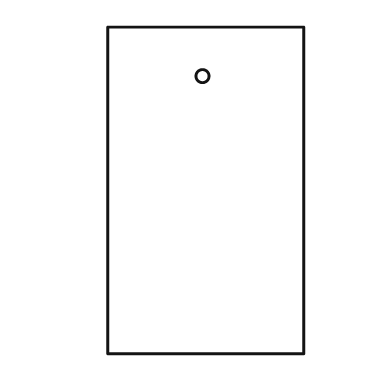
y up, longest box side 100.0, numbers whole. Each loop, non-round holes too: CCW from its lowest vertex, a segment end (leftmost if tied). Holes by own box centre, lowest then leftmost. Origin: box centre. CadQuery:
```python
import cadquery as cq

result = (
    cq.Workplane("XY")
    .moveTo(-30.0, -50.0)
    .lineTo(30.0, -50.0)
    .lineTo(30.0, 50.0)
    .lineTo(-30.0, 50.0)
    .close()
    .moveTo(-1.0, 35.0)
    .circle(2.0)
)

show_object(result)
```